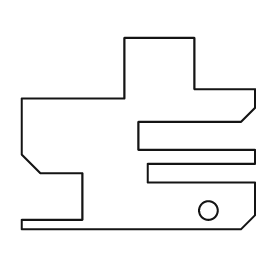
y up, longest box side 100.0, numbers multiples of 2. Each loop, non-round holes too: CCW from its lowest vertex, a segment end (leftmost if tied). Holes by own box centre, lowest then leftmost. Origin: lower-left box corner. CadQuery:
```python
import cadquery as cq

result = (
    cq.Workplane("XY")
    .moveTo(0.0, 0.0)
    .lineTo(94.0, 0.0)
    .lineTo(100.0, 6.0)
    .lineTo(100.0, 20.0)
    .lineTo(54.0, 20.0)
    .lineTo(54.0, 28.0)
    .lineTo(100.0, 28.0)
    .lineTo(100.0, 34.0)
    .lineTo(50.0, 34.0)
    .lineTo(50.0, 46.0)
    .lineTo(94.0, 46.0)
    .lineTo(100.0, 52.0)
    .lineTo(100.0, 60.0)
    .lineTo(74.0, 60.0)
    .lineTo(74.0, 82.0)
    .lineTo(44.0, 82.0)
    .lineTo(44.0, 56.0)
    .lineTo(0.0, 56.0)
    .lineTo(0.0, 32.0)
    .lineTo(8.0, 24.0)
    .lineTo(26.0, 24.0)
    .lineTo(26.0, 4.0)
    .lineTo(0.0, 4.0)
    .close()
    .moveTo(80.0, 8.0)
    .circle(4.0)
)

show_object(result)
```